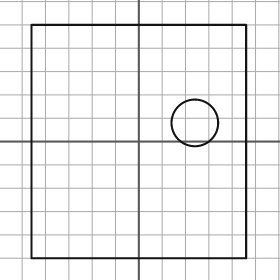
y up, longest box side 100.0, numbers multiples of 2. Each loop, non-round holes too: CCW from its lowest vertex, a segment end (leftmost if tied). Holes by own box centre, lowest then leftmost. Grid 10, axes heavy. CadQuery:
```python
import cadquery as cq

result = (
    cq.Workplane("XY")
    .moveTo(-46.0, -50.0)
    .lineTo(46.0, -50.0)
    .lineTo(46.0, 50.0)
    .lineTo(-46.0, 50.0)
    .close()
    .moveTo(24.0, 8.0)
    .circle(10.0)
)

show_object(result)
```